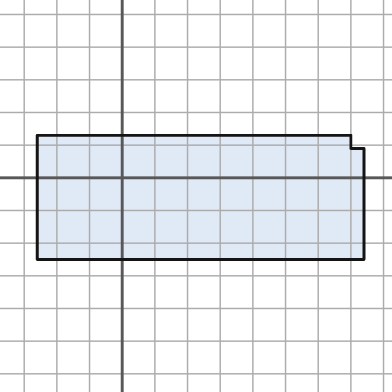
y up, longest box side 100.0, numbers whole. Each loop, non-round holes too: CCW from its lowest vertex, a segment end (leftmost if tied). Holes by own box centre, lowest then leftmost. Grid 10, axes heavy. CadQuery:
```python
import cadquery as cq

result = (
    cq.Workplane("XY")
    .moveTo(-26.0, -25.0)
    .lineTo(74.0, -25.0)
    .lineTo(74.0, 9.0)
    .lineTo(70.0, 9.0)
    .lineTo(70.0, 13.0)
    .lineTo(-26.0, 13.0)
    .close()
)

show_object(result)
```